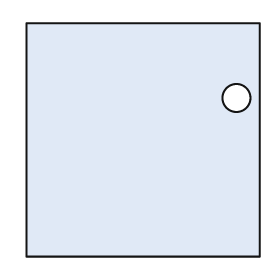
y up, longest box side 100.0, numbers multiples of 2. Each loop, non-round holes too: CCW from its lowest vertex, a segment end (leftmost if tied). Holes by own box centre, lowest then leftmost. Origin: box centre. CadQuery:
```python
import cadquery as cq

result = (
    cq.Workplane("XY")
    .moveTo(-50.0, -50.0)
    .lineTo(50.0, -50.0)
    .lineTo(50.0, 50.0)
    .lineTo(-50.0, 50.0)
    .close()
    .moveTo(40.0, 18.0)
    .circle(6.0)
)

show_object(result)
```